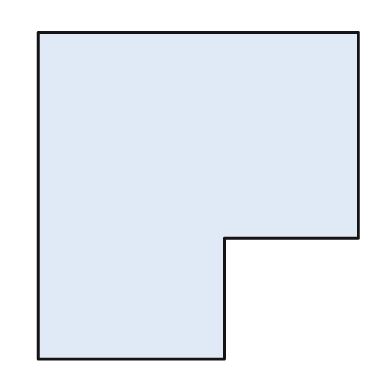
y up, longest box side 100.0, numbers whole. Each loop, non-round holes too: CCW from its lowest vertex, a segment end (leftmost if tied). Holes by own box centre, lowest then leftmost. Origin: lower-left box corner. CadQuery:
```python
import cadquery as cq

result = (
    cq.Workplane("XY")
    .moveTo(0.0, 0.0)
    .lineTo(57.0, 0.0)
    .lineTo(57.0, 37.0)
    .lineTo(98.0, 37.0)
    .lineTo(98.0, 100.0)
    .lineTo(0.0, 100.0)
    .close()
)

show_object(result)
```